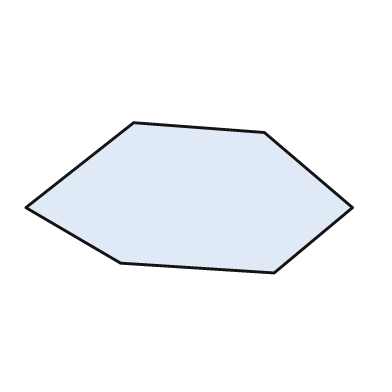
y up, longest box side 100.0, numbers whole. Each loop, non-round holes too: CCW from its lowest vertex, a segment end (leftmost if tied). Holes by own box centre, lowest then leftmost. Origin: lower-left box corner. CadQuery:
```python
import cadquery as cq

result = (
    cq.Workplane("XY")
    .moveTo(76.0, 0.0)
    .lineTo(100.0, 20.0)
    .lineTo(73.0, 43.0)
    .lineTo(33.0, 46.0)
    .lineTo(0.0, 20.0)
    .lineTo(29.0, 3.0)
    .close()
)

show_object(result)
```